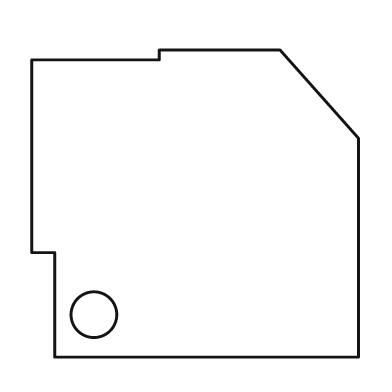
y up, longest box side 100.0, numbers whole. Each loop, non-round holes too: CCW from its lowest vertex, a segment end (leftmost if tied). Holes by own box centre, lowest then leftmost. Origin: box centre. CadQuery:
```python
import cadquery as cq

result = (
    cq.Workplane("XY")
    .moveTo(-43.0, -47.0)
    .lineTo(50.0, -47.0)
    .lineTo(50.0, 20.0)
    .lineTo(26.0, 47.0)
    .lineTo(-11.0, 47.0)
    .lineTo(-11.0, 44.0)
    .lineTo(-50.0, 44.0)
    .lineTo(-50.0, -15.0)
    .lineTo(-43.0, -15.0)
    .close()
    .moveTo(-31.0, -34.0)
    .circle(7.0)
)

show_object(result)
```